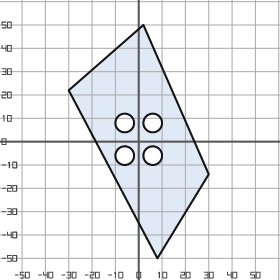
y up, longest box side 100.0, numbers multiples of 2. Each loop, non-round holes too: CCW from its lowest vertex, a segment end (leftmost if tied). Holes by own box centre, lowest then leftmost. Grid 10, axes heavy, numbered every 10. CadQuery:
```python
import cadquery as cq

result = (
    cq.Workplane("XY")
    .moveTo(8.0, -50.0)
    .lineTo(30.0, -14.0)
    .lineTo(2.0, 50.0)
    .lineTo(-30.0, 22.0)
    .close()
    .moveTo(-6.0, -6.0)
    .circle(4.0)
    .moveTo(6.0, -6.0)
    .circle(4.0)
    .moveTo(-6.0, 8.0)
    .circle(4.0)
    .moveTo(6.0, 8.0)
    .circle(4.0)
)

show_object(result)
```